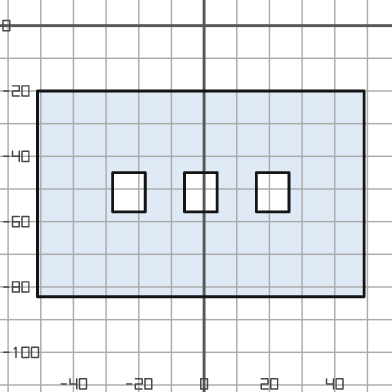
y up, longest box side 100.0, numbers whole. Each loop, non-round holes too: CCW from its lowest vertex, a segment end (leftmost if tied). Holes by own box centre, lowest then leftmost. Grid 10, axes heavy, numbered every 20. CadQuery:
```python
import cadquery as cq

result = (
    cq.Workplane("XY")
    .moveTo(-51.0, -83.0)
    .lineTo(49.0, -83.0)
    .lineTo(49.0, -20.0)
    .lineTo(-51.0, -20.0)
    .close()
    .moveTo(-28.0, -57.0)
    .lineTo(-18.0, -57.0)
    .lineTo(-18.0, -45.0)
    .lineTo(-28.0, -45.0)
    .close()
    .moveTo(-6.0, -57.0)
    .lineTo(4.0, -57.0)
    .lineTo(4.0, -45.0)
    .lineTo(-6.0, -45.0)
    .close()
    .moveTo(16.0, -57.0)
    .lineTo(26.0, -57.0)
    .lineTo(26.0, -45.0)
    .lineTo(16.0, -45.0)
    .close()
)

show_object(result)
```